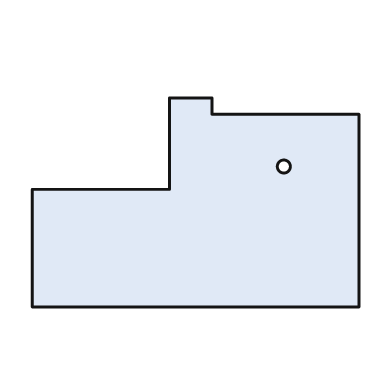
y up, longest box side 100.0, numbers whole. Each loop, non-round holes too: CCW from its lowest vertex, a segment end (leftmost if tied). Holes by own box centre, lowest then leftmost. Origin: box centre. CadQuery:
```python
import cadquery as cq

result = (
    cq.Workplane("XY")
    .moveTo(-50.0, -32.0)
    .lineTo(50.0, -32.0)
    .lineTo(50.0, 27.0)
    .lineTo(5.0, 27.0)
    .lineTo(5.0, 32.0)
    .lineTo(-8.0, 32.0)
    .lineTo(-8.0, 4.0)
    .lineTo(-50.0, 4.0)
    .close()
    .moveTo(27.0, 11.0)
    .circle(2.0)
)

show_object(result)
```